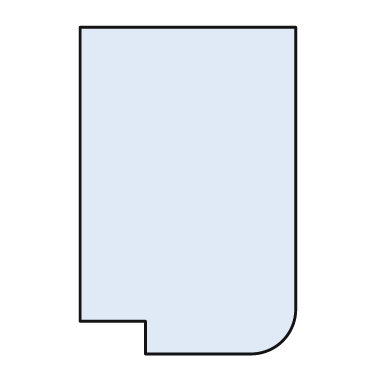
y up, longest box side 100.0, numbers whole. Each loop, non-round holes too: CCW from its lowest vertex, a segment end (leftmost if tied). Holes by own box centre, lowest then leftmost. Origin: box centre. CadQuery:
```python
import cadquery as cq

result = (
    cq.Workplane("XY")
    .moveTo(-13.0, -50.0)
    .lineTo(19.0, -50.0)
    .threePointArc((29.0, -46.0), (33.0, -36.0))
    .lineTo(33.0, 50.0)
    .lineTo(-33.0, 50.0)
    .lineTo(-33.0, -40.0)
    .lineTo(-13.0, -40.0)
    .close()
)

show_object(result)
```